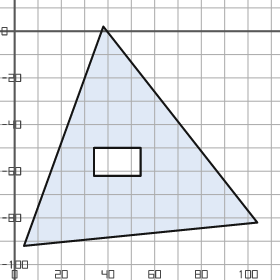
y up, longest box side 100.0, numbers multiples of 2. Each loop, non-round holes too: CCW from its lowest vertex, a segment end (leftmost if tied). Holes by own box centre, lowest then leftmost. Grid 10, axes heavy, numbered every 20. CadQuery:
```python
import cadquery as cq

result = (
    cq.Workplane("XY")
    .moveTo(4.0, -92.0)
    .lineTo(104.0, -82.0)
    .lineTo(38.0, 2.0)
    .close()
    .moveTo(34.0, -62.0)
    .lineTo(54.0, -62.0)
    .lineTo(54.0, -50.0)
    .lineTo(34.0, -50.0)
    .close()
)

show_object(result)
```